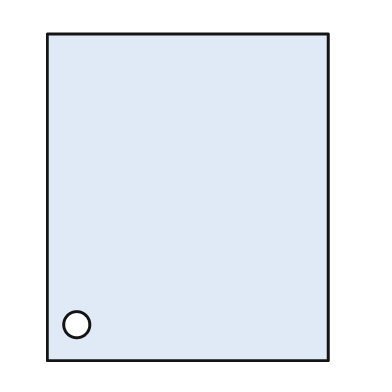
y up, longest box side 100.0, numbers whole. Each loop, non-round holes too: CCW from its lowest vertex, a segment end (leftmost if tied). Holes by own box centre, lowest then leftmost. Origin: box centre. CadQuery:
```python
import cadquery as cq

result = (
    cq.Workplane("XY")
    .moveTo(-43.0, -50.0)
    .lineTo(43.0, -50.0)
    .lineTo(43.0, 50.0)
    .lineTo(-43.0, 50.0)
    .close()
    .moveTo(-34.0, -39.0)
    .circle(4.0)
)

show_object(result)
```